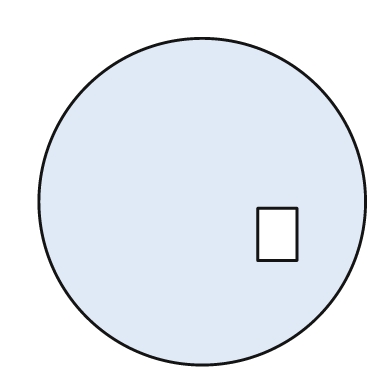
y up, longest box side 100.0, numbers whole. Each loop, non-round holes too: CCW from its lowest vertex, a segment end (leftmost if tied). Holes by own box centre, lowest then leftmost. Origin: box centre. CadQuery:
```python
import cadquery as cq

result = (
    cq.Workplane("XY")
    .moveTo(0.0, 0.0)
    .circle(50.0)
    .moveTo(17.0, -18.0)
    .lineTo(29.0, -18.0)
    .lineTo(29.0, -2.0)
    .lineTo(17.0, -2.0)
    .close()
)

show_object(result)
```